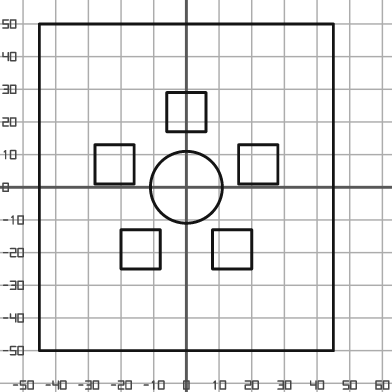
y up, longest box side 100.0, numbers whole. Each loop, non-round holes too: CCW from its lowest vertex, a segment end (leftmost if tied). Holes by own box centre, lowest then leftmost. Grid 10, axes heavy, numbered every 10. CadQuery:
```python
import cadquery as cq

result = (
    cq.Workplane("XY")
    .moveTo(-45.0, -50.0)
    .lineTo(45.0, -50.0)
    .lineTo(45.0, 50.0)
    .lineTo(-45.0, 50.0)
    .close()
    .moveTo(-20.0, -25.0)
    .lineTo(-8.0, -25.0)
    .lineTo(-8.0, -13.0)
    .lineTo(-20.0, -13.0)
    .close()
    .moveTo(8.0, -25.0)
    .lineTo(20.0, -25.0)
    .lineTo(20.0, -13.0)
    .lineTo(8.0, -13.0)
    .close()
    .moveTo(0.0, 0.0)
    .circle(11.0)
    .moveTo(-28.0, 1.0)
    .lineTo(-16.0, 1.0)
    .lineTo(-16.0, 13.0)
    .lineTo(-28.0, 13.0)
    .close()
    .moveTo(16.0, 1.0)
    .lineTo(28.0, 1.0)
    .lineTo(28.0, 13.0)
    .lineTo(16.0, 13.0)
    .close()
    .moveTo(-6.0, 17.0)
    .lineTo(6.0, 17.0)
    .lineTo(6.0, 29.0)
    .lineTo(-6.0, 29.0)
    .close()
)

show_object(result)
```